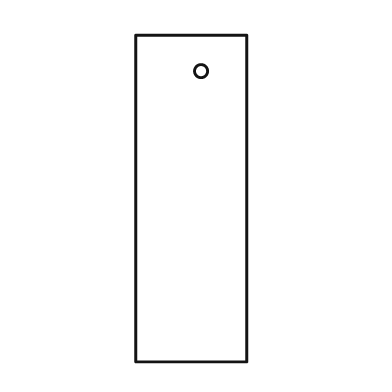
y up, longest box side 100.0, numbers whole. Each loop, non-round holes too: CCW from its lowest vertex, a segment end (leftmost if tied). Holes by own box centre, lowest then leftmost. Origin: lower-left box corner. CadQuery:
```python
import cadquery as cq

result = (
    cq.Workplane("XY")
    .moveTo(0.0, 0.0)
    .lineTo(34.0, 0.0)
    .lineTo(34.0, 100.0)
    .lineTo(0.0, 100.0)
    .close()
    .moveTo(20.0, 89.0)
    .circle(2.0)
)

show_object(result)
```